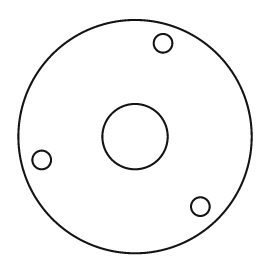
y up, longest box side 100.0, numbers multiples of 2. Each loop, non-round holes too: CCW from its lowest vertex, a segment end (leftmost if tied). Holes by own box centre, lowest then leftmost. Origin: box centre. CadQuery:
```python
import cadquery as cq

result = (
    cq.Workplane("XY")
    .moveTo(0.0, 0.0)
    .circle(50.0)
    .moveTo(28.0, -30.0)
    .circle(4.0)
    .moveTo(-40.0, -10.0)
    .circle(4.0)
    .moveTo(0.0, 0.0)
    .circle(14.0)
    .moveTo(12.0, 40.0)
    .circle(4.0)
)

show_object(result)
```